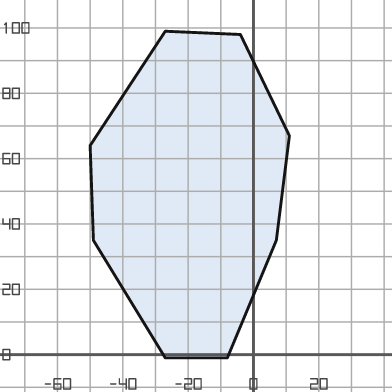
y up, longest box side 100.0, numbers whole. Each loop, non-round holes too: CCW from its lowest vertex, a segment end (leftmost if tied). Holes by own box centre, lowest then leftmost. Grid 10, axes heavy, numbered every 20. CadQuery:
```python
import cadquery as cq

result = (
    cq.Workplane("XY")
    .moveTo(-27.0, -1.0)
    .lineTo(-8.0, -1.0)
    .lineTo(7.0, 35.0)
    .lineTo(11.0, 67.0)
    .lineTo(-4.0, 98.0)
    .lineTo(-27.0, 99.0)
    .lineTo(-50.0, 64.0)
    .lineTo(-49.0, 35.0)
    .close()
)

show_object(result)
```